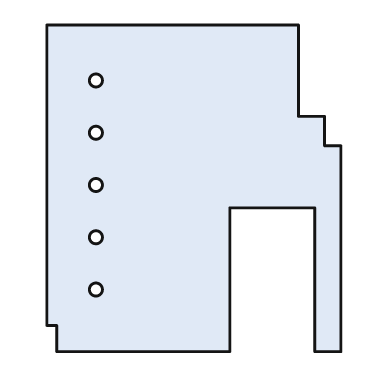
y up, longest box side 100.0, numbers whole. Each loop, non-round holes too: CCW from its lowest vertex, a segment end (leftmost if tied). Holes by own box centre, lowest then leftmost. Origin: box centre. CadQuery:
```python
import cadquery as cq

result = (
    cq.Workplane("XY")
    .moveTo(-42.0, -50.0)
    .lineTo(11.0, -50.0)
    .lineTo(11.0, -6.0)
    .lineTo(37.0, -6.0)
    .lineTo(37.0, -50.0)
    .lineTo(45.0, -50.0)
    .lineTo(45.0, 13.0)
    .lineTo(40.0, 13.0)
    .lineTo(40.0, 22.0)
    .lineTo(32.0, 22.0)
    .lineTo(32.0, 50.0)
    .lineTo(-45.0, 50.0)
    .lineTo(-45.0, -42.0)
    .lineTo(-42.0, -42.0)
    .close()
    .moveTo(-30.0, -31.0)
    .circle(2.0)
    .moveTo(-30.0, -15.0)
    .circle(2.0)
    .moveTo(-30.0, 1.0)
    .circle(2.0)
    .moveTo(-30.0, 17.0)
    .circle(2.0)
    .moveTo(-30.0, 33.0)
    .circle(2.0)
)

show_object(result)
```